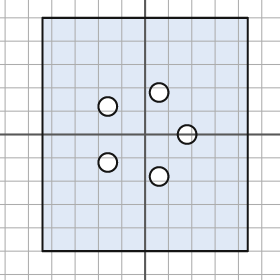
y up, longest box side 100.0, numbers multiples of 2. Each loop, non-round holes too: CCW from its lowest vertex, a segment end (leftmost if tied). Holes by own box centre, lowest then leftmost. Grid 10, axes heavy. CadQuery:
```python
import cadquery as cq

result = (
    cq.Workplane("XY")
    .moveTo(-44.0, -50.0)
    .lineTo(44.0, -50.0)
    .lineTo(44.0, 50.0)
    .lineTo(-44.0, 50.0)
    .close()
    .moveTo(6.0, -18.0)
    .circle(4.0)
    .moveTo(-16.0, -12.0)
    .circle(4.0)
    .moveTo(18.0, 0.0)
    .circle(4.0)
    .moveTo(-16.0, 12.0)
    .circle(4.0)
    .moveTo(6.0, 18.0)
    .circle(4.0)
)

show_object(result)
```